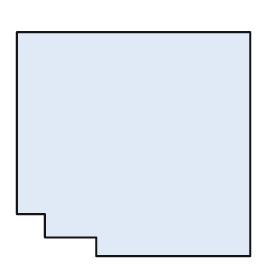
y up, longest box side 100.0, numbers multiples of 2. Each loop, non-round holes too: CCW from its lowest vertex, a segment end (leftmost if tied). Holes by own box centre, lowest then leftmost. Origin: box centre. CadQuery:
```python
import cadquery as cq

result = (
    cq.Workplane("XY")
    .moveTo(-16.0, -48.0)
    .lineTo(50.0, -48.0)
    .lineTo(50.0, 48.0)
    .lineTo(-50.0, 48.0)
    .lineTo(-50.0, -30.0)
    .lineTo(-38.0, -30.0)
    .lineTo(-38.0, -40.0)
    .lineTo(-16.0, -40.0)
    .close()
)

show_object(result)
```